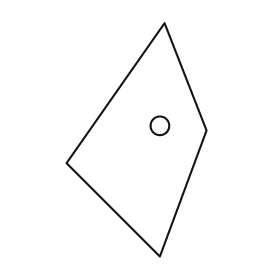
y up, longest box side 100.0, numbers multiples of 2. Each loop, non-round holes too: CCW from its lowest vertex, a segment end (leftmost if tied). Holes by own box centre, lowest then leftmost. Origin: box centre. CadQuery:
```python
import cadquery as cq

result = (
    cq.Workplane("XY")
    .moveTo(10.0, -50.0)
    .lineTo(30.0, 4.0)
    .lineTo(12.0, 50.0)
    .lineTo(-30.0, -10.0)
    .close()
    .moveTo(10.0, 6.0)
    .circle(4.0)
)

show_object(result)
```